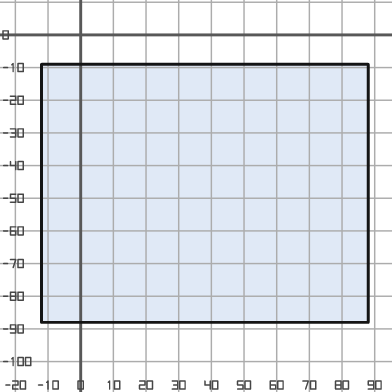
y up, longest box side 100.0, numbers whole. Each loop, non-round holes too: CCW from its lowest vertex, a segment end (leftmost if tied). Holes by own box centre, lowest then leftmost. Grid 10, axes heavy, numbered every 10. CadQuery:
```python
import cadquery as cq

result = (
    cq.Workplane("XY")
    .moveTo(-12.0, -88.0)
    .lineTo(88.0, -88.0)
    .lineTo(88.0, -9.0)
    .lineTo(-12.0, -9.0)
    .close()
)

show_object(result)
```